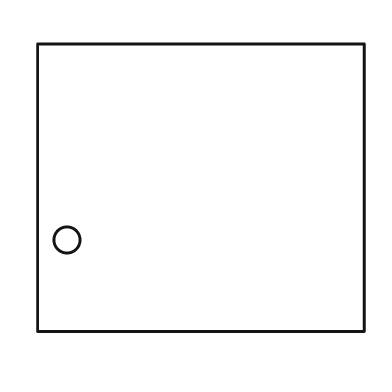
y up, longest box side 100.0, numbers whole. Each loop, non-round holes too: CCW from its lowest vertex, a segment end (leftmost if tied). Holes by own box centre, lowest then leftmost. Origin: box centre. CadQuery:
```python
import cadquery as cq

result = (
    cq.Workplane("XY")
    .moveTo(-50.0, -44.0)
    .lineTo(50.0, -44.0)
    .lineTo(50.0, 44.0)
    .lineTo(-50.0, 44.0)
    .close()
    .moveTo(-41.0, -16.0)
    .circle(4.0)
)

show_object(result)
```